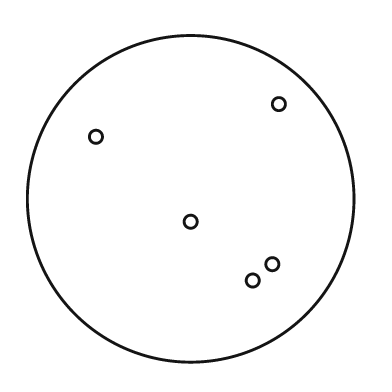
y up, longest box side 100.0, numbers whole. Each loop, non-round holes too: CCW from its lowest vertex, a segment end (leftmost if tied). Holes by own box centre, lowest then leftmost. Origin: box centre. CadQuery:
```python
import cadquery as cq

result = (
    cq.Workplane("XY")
    .moveTo(0.0, 0.0)
    .circle(50.0)
    .moveTo(19.0, -25.0)
    .circle(2.0)
    .moveTo(25.0, -20.0)
    .circle(2.0)
    .moveTo(0.0, -7.0)
    .circle(2.0)
    .moveTo(-29.0, 19.0)
    .circle(2.0)
    .moveTo(27.0, 29.0)
    .circle(2.0)
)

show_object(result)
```